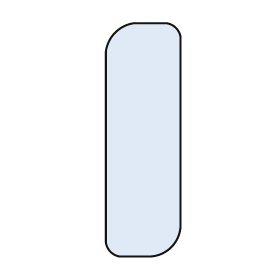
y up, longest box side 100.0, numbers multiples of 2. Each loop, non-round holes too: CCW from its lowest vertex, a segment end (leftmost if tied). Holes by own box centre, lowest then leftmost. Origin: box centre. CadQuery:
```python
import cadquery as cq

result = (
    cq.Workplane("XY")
    .moveTo(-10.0, -50.0)
    .lineTo(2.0, -50.0)
    .threePointArc((12.0, -46.0), (16.0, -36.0))
    .lineTo(16.0, 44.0)
    .threePointArc((14.0, 48.0), (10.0, 50.0))
    .lineTo(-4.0, 50.0)
    .threePointArc((-12.0, 46.0), (-16.0, 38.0))
    .lineTo(-16.0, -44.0)
    .threePointArc((-14.0, -48.0), (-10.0, -50.0))
    .close()
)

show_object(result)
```